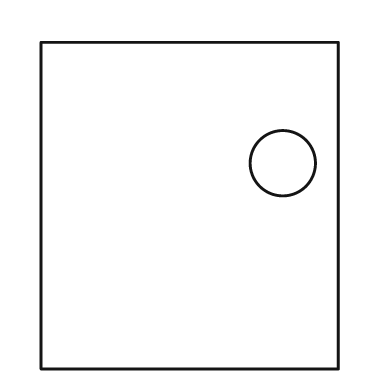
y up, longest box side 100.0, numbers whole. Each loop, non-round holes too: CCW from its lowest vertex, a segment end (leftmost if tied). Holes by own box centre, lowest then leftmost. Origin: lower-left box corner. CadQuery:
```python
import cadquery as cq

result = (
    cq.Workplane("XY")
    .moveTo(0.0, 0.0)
    .lineTo(91.0, 0.0)
    .lineTo(91.0, 100.0)
    .lineTo(0.0, 100.0)
    .close()
    .moveTo(74.0, 63.0)
    .circle(10.0)
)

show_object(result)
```